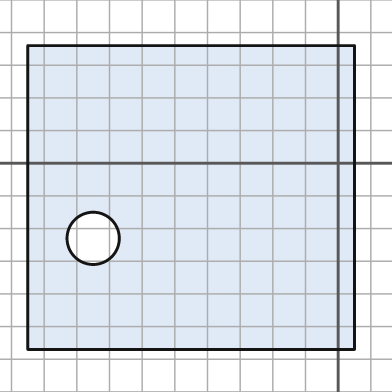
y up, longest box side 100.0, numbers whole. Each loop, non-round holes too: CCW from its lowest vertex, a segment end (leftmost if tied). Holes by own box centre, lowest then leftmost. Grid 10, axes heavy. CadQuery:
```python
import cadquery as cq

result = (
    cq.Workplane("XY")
    .moveTo(-95.0, -57.0)
    .lineTo(5.0, -57.0)
    .lineTo(5.0, 36.0)
    .lineTo(-95.0, 36.0)
    .close()
    .moveTo(-75.0, -23.0)
    .circle(8.0)
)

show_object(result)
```